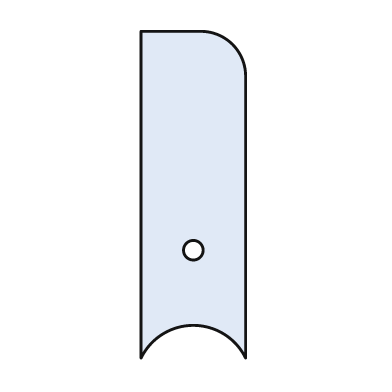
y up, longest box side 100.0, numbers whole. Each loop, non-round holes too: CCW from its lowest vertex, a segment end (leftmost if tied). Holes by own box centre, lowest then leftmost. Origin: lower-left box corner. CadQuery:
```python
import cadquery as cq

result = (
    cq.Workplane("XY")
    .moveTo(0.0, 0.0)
    .threePointArc((16.0, 10.0), (32.0, 0.0))
    .lineTo(32.0, 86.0)
    .threePointArc((28.0, 96.0), (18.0, 100.0))
    .lineTo(0.0, 100.0)
    .close()
    .moveTo(16.0, 33.0)
    .circle(3.0)
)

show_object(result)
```